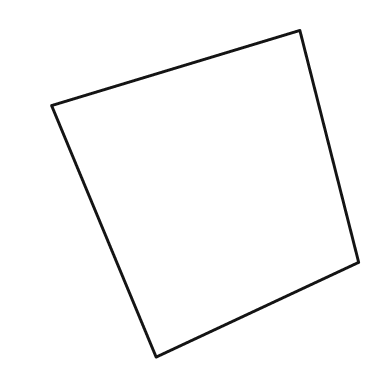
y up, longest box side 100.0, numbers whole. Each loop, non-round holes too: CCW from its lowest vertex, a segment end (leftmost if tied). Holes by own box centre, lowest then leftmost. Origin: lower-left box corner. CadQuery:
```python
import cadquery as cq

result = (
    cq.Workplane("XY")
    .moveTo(32.0, 0.0)
    .lineTo(94.0, 29.0)
    .lineTo(76.0, 100.0)
    .lineTo(0.0, 77.0)
    .close()
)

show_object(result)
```